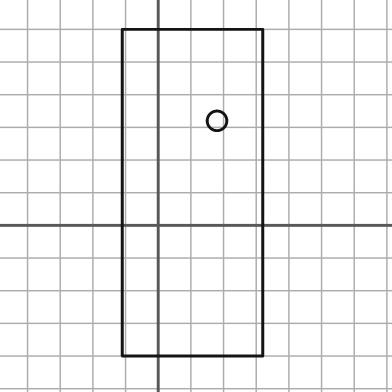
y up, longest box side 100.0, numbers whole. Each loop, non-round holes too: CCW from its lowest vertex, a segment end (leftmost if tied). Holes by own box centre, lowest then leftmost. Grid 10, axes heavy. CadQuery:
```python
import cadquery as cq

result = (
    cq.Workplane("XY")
    .moveTo(-11.0, -40.0)
    .lineTo(32.0, -40.0)
    .lineTo(32.0, 60.0)
    .lineTo(-11.0, 60.0)
    .close()
    .moveTo(18.0, 32.0)
    .circle(3.0)
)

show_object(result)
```